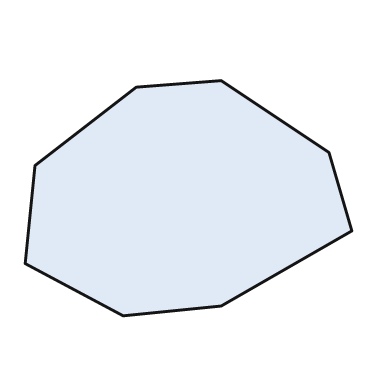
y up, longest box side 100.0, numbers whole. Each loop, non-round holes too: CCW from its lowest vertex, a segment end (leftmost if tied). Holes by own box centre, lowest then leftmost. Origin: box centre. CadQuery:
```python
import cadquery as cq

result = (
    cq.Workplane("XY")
    .moveTo(-20.0, -36.0)
    .lineTo(10.0, -33.0)
    .lineTo(50.0, -10.0)
    .lineTo(43.0, 14.0)
    .lineTo(10.0, 36.0)
    .lineTo(-16.0, 34.0)
    .lineTo(-47.0, 10.0)
    .lineTo(-50.0, -20.0)
    .close()
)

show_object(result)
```